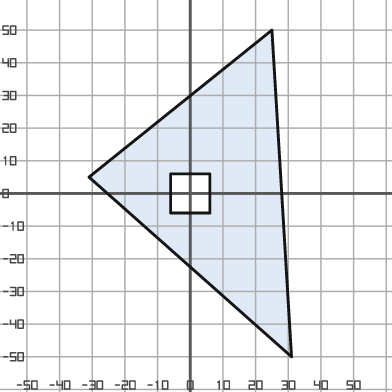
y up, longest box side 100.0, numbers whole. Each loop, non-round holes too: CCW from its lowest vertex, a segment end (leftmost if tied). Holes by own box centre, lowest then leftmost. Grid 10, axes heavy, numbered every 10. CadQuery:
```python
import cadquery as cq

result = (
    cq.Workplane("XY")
    .moveTo(31.0, -50.0)
    .lineTo(25.0, 50.0)
    .lineTo(-31.0, 5.0)
    .close()
    .moveTo(-6.0, -6.0)
    .lineTo(6.0, -6.0)
    .lineTo(6.0, 6.0)
    .lineTo(-6.0, 6.0)
    .close()
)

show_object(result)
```